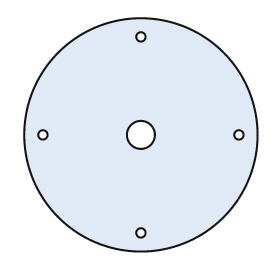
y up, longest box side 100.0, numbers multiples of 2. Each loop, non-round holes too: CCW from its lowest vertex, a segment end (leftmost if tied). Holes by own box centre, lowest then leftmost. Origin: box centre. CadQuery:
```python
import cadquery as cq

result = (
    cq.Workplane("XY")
    .moveTo(0.0, 0.0)
    .circle(50.0)
    .moveTo(0.0, -42.0)
    .circle(2.0)
    .moveTo(-42.0, 0.0)
    .circle(2.0)
    .moveTo(0.0, 0.0)
    .circle(6.0)
    .moveTo(42.0, 0.0)
    .circle(2.0)
    .moveTo(0.0, 42.0)
    .circle(2.0)
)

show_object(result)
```